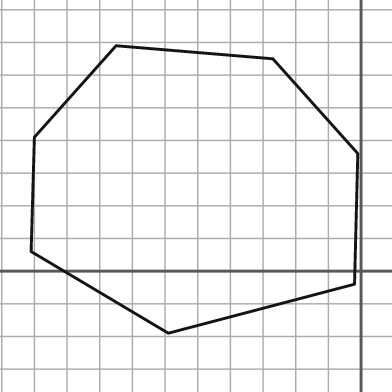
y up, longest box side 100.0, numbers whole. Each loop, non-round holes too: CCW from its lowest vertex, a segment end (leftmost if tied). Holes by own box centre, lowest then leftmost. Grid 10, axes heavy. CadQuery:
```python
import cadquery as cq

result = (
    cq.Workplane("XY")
    .moveTo(-59.0, -19.0)
    .lineTo(-2.0, -4.0)
    .lineTo(-1.0, 36.0)
    .lineTo(-27.0, 65.0)
    .lineTo(-75.0, 69.0)
    .lineTo(-100.0, 41.0)
    .lineTo(-101.0, 6.0)
    .close()
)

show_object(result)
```